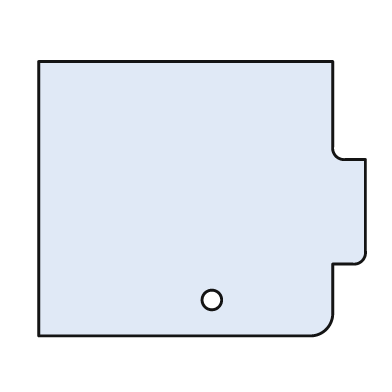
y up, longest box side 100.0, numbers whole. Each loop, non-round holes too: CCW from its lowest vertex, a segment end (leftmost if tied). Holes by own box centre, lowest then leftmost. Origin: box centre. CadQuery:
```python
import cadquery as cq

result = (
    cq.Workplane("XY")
    .moveTo(-50.0, -42.0)
    .lineTo(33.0, -42.0)
    .threePointArc((38.0, -40.0), (40.0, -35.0))
    .lineTo(40.0, -20.0)
    .lineTo(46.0, -20.0)
    .threePointArc((49.0, -19.0), (50.0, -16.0))
    .lineTo(50.0, 12.0)
    .lineTo(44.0, 12.0)
    .threePointArc((41.0, 13.0), (40.0, 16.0))
    .lineTo(40.0, 42.0)
    .lineTo(-50.0, 42.0)
    .close()
    .moveTo(3.0, -31.0)
    .circle(3.0)
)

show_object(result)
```